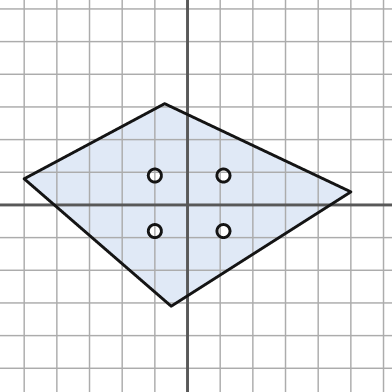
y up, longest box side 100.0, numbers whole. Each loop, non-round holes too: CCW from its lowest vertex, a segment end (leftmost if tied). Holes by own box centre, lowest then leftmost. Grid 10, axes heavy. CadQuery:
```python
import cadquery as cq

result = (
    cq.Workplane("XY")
    .moveTo(-5.0, -31.0)
    .lineTo(50.0, 4.0)
    .lineTo(-7.0, 31.0)
    .lineTo(-50.0, 8.0)
    .close()
    .moveTo(-10.0, -8.0)
    .circle(2.0)
    .moveTo(11.0, -8.0)
    .circle(2.0)
    .moveTo(-10.0, 9.0)
    .circle(2.0)
    .moveTo(11.0, 9.0)
    .circle(2.0)
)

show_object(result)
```